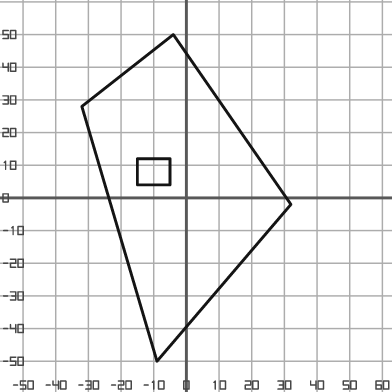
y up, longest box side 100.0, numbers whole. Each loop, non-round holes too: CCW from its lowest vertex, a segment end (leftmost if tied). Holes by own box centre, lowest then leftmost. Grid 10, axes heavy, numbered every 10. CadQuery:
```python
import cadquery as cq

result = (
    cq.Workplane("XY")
    .moveTo(-9.0, -50.0)
    .lineTo(32.0, -2.0)
    .lineTo(-4.0, 50.0)
    .lineTo(-32.0, 28.0)
    .close()
    .moveTo(-15.0, 4.0)
    .lineTo(-5.0, 4.0)
    .lineTo(-5.0, 12.0)
    .lineTo(-15.0, 12.0)
    .close()
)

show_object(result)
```